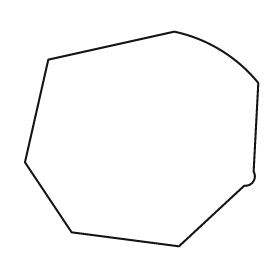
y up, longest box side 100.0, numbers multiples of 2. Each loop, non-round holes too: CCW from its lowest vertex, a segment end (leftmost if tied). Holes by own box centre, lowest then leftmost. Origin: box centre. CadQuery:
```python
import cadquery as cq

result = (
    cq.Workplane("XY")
    .moveTo(16.0, -46.0)
    .lineTo(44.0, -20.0)
    .threePointArc((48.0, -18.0), (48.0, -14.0))
    .lineTo(50.0, 24.0)
    .threePointArc((34.0, 38.0), (14.0, 46.0))
    .lineTo(-40.0, 34.0)
    .lineTo(-50.0, -10.0)
    .lineTo(-30.0, -40.0)
    .close()
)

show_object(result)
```